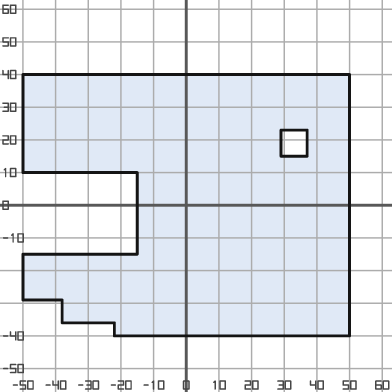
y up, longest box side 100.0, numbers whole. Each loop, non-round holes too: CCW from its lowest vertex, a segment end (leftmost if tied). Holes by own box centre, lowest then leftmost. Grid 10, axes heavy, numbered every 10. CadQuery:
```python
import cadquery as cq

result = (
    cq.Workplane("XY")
    .moveTo(-22.0, -40.0)
    .lineTo(50.0, -40.0)
    .lineTo(50.0, 40.0)
    .lineTo(-50.0, 40.0)
    .lineTo(-50.0, 10.0)
    .lineTo(-15.0, 10.0)
    .lineTo(-15.0, -15.0)
    .lineTo(-50.0, -15.0)
    .lineTo(-50.0, -29.0)
    .lineTo(-38.0, -29.0)
    .lineTo(-38.0, -36.0)
    .lineTo(-22.0, -36.0)
    .close()
    .moveTo(29.0, 15.0)
    .lineTo(37.0, 15.0)
    .lineTo(37.0, 23.0)
    .lineTo(29.0, 23.0)
    .close()
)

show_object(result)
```